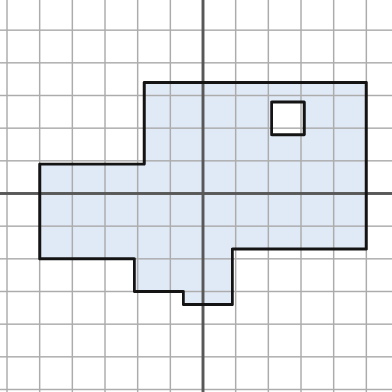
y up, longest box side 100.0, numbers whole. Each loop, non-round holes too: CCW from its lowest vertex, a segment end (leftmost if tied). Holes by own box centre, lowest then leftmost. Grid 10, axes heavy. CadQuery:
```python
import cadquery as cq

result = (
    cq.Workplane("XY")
    .moveTo(-6.0, -34.0)
    .lineTo(9.0, -34.0)
    .lineTo(9.0, -17.0)
    .lineTo(50.0, -17.0)
    .lineTo(50.0, 34.0)
    .lineTo(-18.0, 34.0)
    .lineTo(-18.0, 9.0)
    .lineTo(-50.0, 9.0)
    .lineTo(-50.0, -20.0)
    .lineTo(-21.0, -20.0)
    .lineTo(-21.0, -30.0)
    .lineTo(-6.0, -30.0)
    .close()
    .moveTo(21.0, 18.0)
    .lineTo(31.0, 18.0)
    .lineTo(31.0, 28.0)
    .lineTo(21.0, 28.0)
    .close()
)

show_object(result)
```